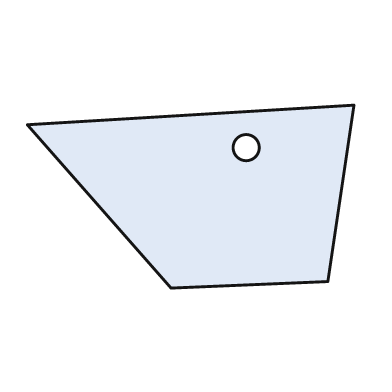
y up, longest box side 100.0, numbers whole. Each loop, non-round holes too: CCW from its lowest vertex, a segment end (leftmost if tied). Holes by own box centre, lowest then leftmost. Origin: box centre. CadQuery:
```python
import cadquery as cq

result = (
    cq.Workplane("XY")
    .moveTo(-6.0, -28.0)
    .lineTo(42.0, -26.0)
    .lineTo(50.0, 28.0)
    .lineTo(-50.0, 22.0)
    .close()
    .moveTo(17.0, 15.0)
    .circle(4.0)
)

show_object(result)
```